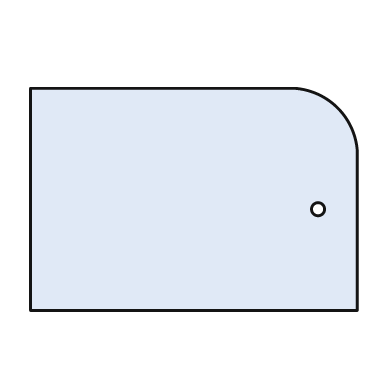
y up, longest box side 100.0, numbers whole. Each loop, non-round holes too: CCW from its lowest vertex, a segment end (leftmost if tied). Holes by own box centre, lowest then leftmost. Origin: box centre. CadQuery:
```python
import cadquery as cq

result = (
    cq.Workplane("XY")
    .moveTo(-50.0, -34.0)
    .lineTo(50.0, -34.0)
    .lineTo(50.0, 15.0)
    .threePointArc((44.0, 28.0), (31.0, 34.0))
    .lineTo(-50.0, 34.0)
    .close()
    .moveTo(38.0, -3.0)
    .circle(2.0)
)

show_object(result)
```